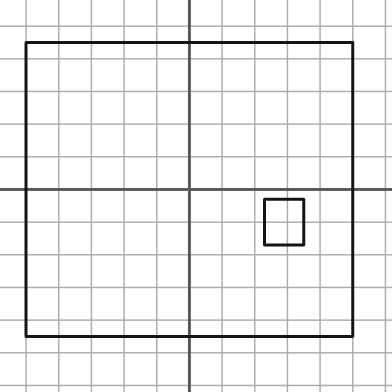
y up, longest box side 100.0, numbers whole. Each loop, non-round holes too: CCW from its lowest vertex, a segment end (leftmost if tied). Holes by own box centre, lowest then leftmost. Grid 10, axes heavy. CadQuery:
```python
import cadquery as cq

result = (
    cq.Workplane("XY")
    .moveTo(-50.0, -45.0)
    .lineTo(50.0, -45.0)
    .lineTo(50.0, 45.0)
    .lineTo(-50.0, 45.0)
    .close()
    .moveTo(23.0, -17.0)
    .lineTo(35.0, -17.0)
    .lineTo(35.0, -3.0)
    .lineTo(23.0, -3.0)
    .close()
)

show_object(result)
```